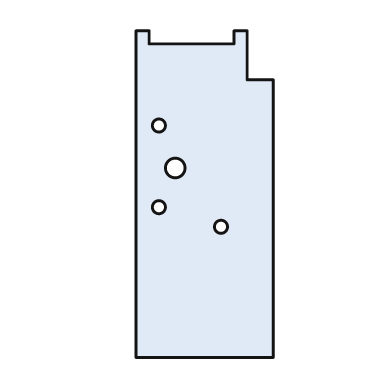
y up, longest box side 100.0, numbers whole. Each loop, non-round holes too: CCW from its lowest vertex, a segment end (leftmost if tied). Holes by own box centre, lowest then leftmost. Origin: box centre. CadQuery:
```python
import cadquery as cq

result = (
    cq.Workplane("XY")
    .moveTo(-21.0, -50.0)
    .lineTo(21.0, -50.0)
    .lineTo(21.0, 35.0)
    .lineTo(13.0, 35.0)
    .lineTo(13.0, 50.0)
    .lineTo(9.0, 50.0)
    .lineTo(9.0, 46.0)
    .lineTo(-17.0, 46.0)
    .lineTo(-17.0, 50.0)
    .lineTo(-21.0, 50.0)
    .close()
    .moveTo(5.0, -10.0)
    .circle(2.0)
    .moveTo(-14.0, -4.0)
    .circle(2.0)
    .moveTo(-9.0, 8.0)
    .circle(3.0)
    .moveTo(-14.0, 21.0)
    .circle(2.0)
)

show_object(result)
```